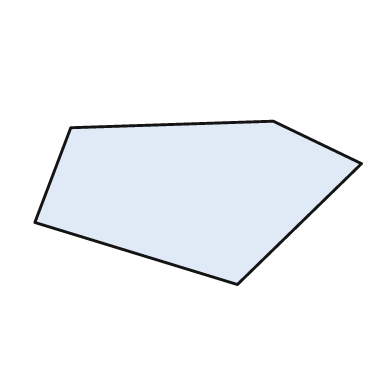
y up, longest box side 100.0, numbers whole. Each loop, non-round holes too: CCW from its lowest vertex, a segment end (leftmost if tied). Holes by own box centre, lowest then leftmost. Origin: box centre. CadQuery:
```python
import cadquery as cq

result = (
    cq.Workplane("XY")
    .moveTo(12.0, -25.0)
    .lineTo(50.0, 12.0)
    .lineTo(23.0, 25.0)
    .lineTo(-39.0, 23.0)
    .lineTo(-50.0, -6.0)
    .close()
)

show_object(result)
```